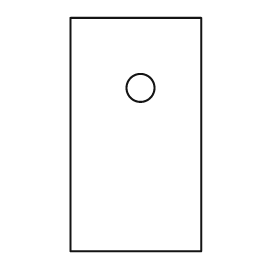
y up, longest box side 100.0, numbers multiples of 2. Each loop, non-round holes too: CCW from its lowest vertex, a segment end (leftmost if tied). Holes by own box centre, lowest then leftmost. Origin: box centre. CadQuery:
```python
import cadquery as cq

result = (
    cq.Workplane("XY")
    .moveTo(-28.0, -50.0)
    .lineTo(28.0, -50.0)
    .lineTo(28.0, 50.0)
    .lineTo(-28.0, 50.0)
    .close()
    .moveTo(2.0, 20.0)
    .circle(6.0)
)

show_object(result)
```